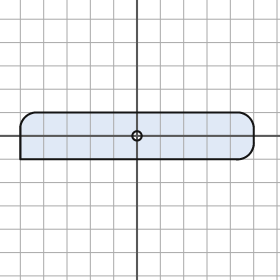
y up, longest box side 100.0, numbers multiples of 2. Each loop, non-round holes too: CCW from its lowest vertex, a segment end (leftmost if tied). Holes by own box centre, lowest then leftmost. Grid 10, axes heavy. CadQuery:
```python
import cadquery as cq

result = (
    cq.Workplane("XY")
    .moveTo(-50.0, -10.0)
    .lineTo(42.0, -10.0)
    .threePointArc((48.0, -8.0), (50.0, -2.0))
    .lineTo(50.0, 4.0)
    .threePointArc((48.0, 8.0), (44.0, 10.0))
    .lineTo(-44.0, 10.0)
    .threePointArc((-48.0, 8.0), (-50.0, 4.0))
    .close()
    .moveTo(0.0, 0.0)
    .circle(2.0)
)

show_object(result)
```